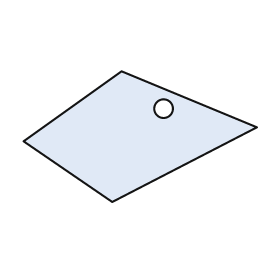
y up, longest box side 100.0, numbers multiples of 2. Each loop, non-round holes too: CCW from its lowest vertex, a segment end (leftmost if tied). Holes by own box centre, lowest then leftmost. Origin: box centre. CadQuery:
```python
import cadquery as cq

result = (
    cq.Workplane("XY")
    .moveTo(-12.0, -28.0)
    .lineTo(50.0, 4.0)
    .lineTo(-8.0, 28.0)
    .lineTo(-50.0, -2.0)
    .close()
    .moveTo(10.0, 12.0)
    .circle(4.0)
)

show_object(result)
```